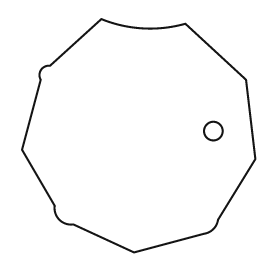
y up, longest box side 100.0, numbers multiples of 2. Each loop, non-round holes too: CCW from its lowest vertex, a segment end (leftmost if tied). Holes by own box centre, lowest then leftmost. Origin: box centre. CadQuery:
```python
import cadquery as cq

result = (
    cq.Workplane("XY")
    .moveTo(-2.0, -50.0)
    .lineTo(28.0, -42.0)
    .threePointArc((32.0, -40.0), (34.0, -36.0))
    .lineTo(50.0, -10.0)
    .lineTo(46.0, 24.0)
    .lineTo(20.0, 48.0)
    .threePointArc((2.0, 46.0), (-16.0, 50.0))
    .lineTo(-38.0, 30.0)
    .threePointArc((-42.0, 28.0), (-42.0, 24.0))
    .lineTo(-50.0, -6.0)
    .lineTo(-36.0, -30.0)
    .threePointArc((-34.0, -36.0), (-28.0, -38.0))
    .close()
    .moveTo(32.0, 2.0)
    .circle(4.0)
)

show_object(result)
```